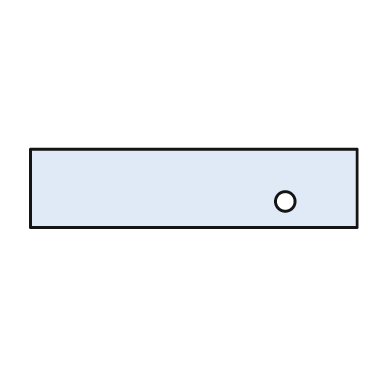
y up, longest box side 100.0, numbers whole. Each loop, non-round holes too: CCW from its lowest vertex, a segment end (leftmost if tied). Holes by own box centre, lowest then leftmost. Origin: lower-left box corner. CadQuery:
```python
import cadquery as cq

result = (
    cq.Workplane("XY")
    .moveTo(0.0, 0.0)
    .lineTo(100.0, 0.0)
    .lineTo(100.0, 24.0)
    .lineTo(0.0, 24.0)
    .close()
    .moveTo(78.0, 8.0)
    .circle(3.0)
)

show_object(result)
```